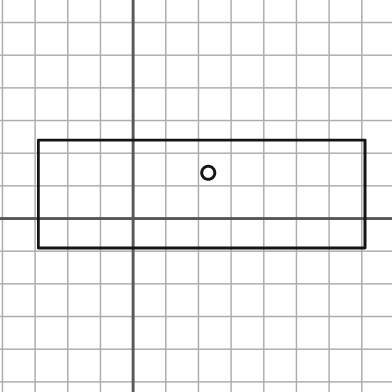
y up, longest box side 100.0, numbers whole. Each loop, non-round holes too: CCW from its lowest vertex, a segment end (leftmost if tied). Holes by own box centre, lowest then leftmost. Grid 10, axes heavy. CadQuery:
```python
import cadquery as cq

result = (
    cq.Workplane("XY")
    .moveTo(-29.0, -9.0)
    .lineTo(71.0, -9.0)
    .lineTo(71.0, 24.0)
    .lineTo(-29.0, 24.0)
    .close()
    .moveTo(23.0, 14.0)
    .circle(2.0)
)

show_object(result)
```